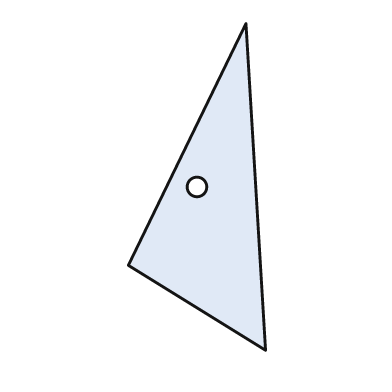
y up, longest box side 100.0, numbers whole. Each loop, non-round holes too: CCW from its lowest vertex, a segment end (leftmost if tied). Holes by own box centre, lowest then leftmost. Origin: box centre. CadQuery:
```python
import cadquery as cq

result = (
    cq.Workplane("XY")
    .moveTo(21.0, -50.0)
    .lineTo(15.0, 50.0)
    .lineTo(-21.0, -24.0)
    .close()
    .moveTo(0.0, 0.0)
    .circle(3.0)
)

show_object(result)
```